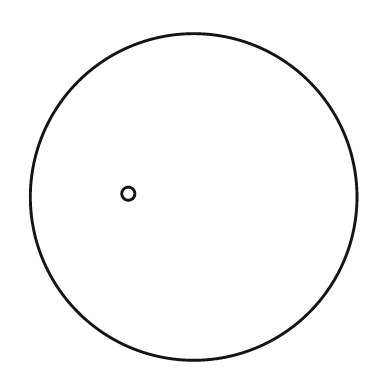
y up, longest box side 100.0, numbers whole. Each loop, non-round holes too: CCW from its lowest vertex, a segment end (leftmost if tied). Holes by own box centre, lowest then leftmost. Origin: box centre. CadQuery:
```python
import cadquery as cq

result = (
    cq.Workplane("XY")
    .moveTo(0.0, 0.0)
    .circle(50.0)
    .moveTo(-20.0, 1.0)
    .circle(2.0)
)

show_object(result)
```